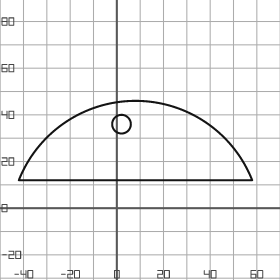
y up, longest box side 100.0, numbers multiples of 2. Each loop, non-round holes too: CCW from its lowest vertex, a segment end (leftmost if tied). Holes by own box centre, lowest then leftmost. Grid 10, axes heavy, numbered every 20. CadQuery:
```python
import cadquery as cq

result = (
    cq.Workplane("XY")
    .moveTo(-42.0, 12.0)
    .lineTo(58.0, 12.0)
    .threePointArc((8.0, 46.0), (-42.0, 12.0))
    .close()
    .moveTo(2.0, 36.0)
    .circle(4.0)
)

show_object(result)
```